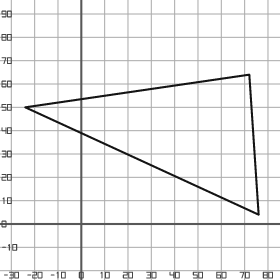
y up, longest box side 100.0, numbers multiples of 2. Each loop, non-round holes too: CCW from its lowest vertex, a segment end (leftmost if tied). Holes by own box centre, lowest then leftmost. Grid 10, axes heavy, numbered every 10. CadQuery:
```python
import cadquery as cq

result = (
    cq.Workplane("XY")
    .moveTo(76.0, 4.0)
    .lineTo(72.0, 64.0)
    .lineTo(-24.0, 50.0)
    .close()
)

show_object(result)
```